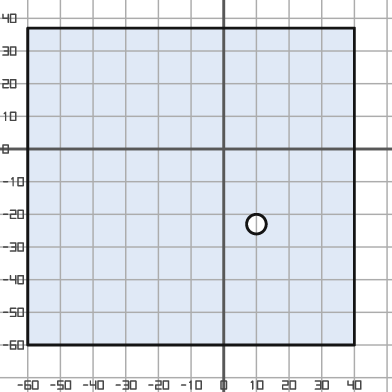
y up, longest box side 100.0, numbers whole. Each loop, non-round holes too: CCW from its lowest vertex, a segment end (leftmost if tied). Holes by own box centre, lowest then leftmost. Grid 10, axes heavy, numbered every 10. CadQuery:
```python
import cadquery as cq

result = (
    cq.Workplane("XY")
    .moveTo(-60.0, -60.0)
    .lineTo(40.0, -60.0)
    .lineTo(40.0, 37.0)
    .lineTo(-60.0, 37.0)
    .close()
    .moveTo(10.0, -23.0)
    .circle(3.0)
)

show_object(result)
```